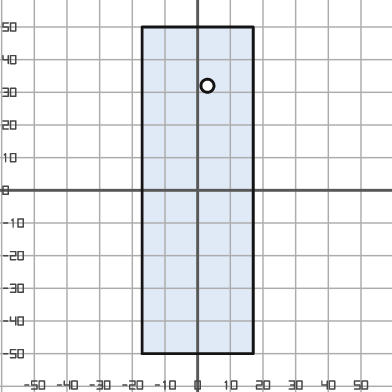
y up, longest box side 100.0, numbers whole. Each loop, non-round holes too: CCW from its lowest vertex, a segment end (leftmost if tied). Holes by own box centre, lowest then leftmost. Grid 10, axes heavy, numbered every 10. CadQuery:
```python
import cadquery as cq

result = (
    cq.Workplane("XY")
    .moveTo(-17.0, -50.0)
    .lineTo(17.0, -50.0)
    .lineTo(17.0, 50.0)
    .lineTo(-17.0, 50.0)
    .close()
    .moveTo(3.0, 32.0)
    .circle(2.0)
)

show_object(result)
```